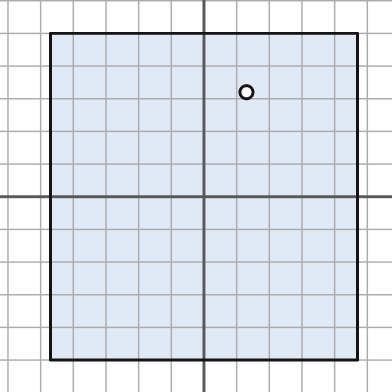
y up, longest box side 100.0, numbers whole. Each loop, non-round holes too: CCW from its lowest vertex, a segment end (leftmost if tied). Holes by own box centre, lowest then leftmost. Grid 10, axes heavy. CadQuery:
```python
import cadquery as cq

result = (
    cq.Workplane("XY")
    .moveTo(-47.0, -50.0)
    .lineTo(47.0, -50.0)
    .lineTo(47.0, 50.0)
    .lineTo(-47.0, 50.0)
    .close()
    .moveTo(13.0, 32.0)
    .circle(2.0)
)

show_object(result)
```